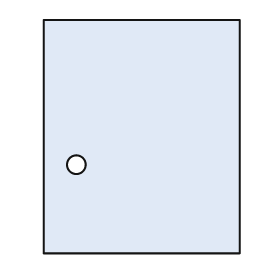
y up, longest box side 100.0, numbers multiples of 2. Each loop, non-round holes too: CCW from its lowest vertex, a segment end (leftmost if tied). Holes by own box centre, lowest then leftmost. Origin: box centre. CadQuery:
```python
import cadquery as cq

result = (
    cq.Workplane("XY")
    .moveTo(-42.0, -50.0)
    .lineTo(42.0, -50.0)
    .lineTo(42.0, 50.0)
    .lineTo(-42.0, 50.0)
    .close()
    .moveTo(-28.0, -12.0)
    .circle(4.0)
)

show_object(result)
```